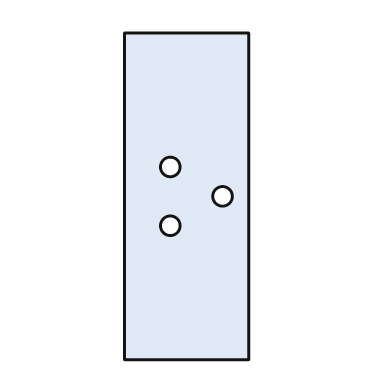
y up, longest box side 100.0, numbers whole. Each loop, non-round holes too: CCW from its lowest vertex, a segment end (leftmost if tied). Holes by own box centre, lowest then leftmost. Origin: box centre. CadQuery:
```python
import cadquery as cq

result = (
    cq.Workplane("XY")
    .moveTo(-19.0, -50.0)
    .lineTo(19.0, -50.0)
    .lineTo(19.0, 50.0)
    .lineTo(-19.0, 50.0)
    .close()
    .moveTo(-5.0, -9.0)
    .circle(3.0)
    .moveTo(11.0, 0.0)
    .circle(3.0)
    .moveTo(-5.0, 9.0)
    .circle(3.0)
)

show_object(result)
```